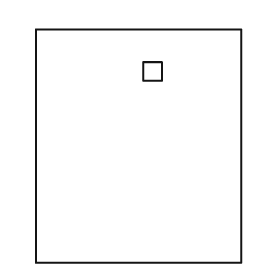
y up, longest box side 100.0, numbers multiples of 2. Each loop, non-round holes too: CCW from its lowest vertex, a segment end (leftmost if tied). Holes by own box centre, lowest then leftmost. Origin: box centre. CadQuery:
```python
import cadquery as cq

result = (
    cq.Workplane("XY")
    .moveTo(-44.0, -50.0)
    .lineTo(44.0, -50.0)
    .lineTo(44.0, 50.0)
    .lineTo(-44.0, 50.0)
    .close()
    .moveTo(2.0, 28.0)
    .lineTo(10.0, 28.0)
    .lineTo(10.0, 36.0)
    .lineTo(2.0, 36.0)
    .close()
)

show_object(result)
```